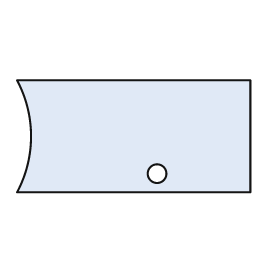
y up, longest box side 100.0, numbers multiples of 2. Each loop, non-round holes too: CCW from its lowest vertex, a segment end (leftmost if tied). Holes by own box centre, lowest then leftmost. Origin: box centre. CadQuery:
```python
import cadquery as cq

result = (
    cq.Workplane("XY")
    .moveTo(-50.0, -24.0)
    .lineTo(50.0, -24.0)
    .lineTo(50.0, 24.0)
    .lineTo(-50.0, 24.0)
    .threePointArc((-44.0, 0.0), (-50.0, -24.0))
    .close()
    .moveTo(10.0, -16.0)
    .circle(4.0)
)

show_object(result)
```